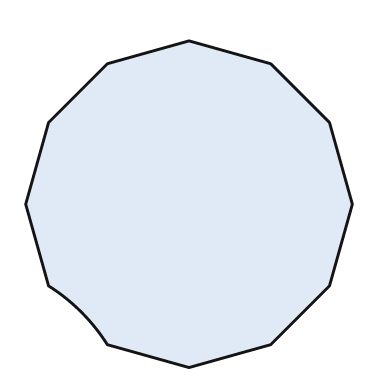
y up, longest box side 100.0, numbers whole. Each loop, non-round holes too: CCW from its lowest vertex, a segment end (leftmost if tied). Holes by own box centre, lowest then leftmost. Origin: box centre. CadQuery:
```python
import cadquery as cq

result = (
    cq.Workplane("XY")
    .moveTo(0.0, -50.0)
    .lineTo(25.0, -43.0)
    .lineTo(43.0, -25.0)
    .lineTo(50.0, 0.0)
    .lineTo(43.0, 25.0)
    .lineTo(25.0, 43.0)
    .lineTo(0.0, 50.0)
    .lineTo(-25.0, 43.0)
    .lineTo(-43.0, 25.0)
    .lineTo(-50.0, 0.0)
    .lineTo(-43.0, -25.0)
    .threePointArc((-33.0, -33.0), (-25.0, -43.0))
    .close()
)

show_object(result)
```